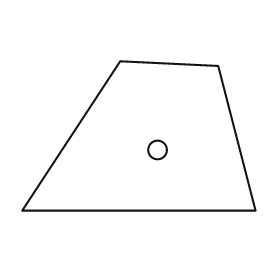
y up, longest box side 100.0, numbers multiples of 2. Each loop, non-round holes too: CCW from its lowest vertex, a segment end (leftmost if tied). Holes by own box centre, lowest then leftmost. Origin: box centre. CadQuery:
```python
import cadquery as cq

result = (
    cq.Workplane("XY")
    .moveTo(-50.0, -32.0)
    .lineTo(50.0, -32.0)
    .lineTo(34.0, 30.0)
    .lineTo(-8.0, 32.0)
    .close()
    .moveTo(8.0, -6.0)
    .circle(4.0)
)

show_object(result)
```